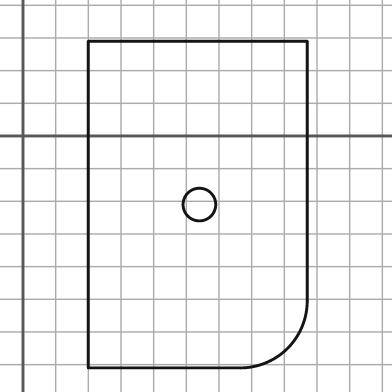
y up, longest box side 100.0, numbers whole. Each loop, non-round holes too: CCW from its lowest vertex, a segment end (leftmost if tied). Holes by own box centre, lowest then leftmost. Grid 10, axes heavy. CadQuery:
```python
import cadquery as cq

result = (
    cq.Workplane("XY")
    .moveTo(20.0, -71.0)
    .lineTo(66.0, -71.0)
    .threePointArc((81.0, -65.0), (87.0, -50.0))
    .lineTo(87.0, 29.0)
    .lineTo(20.0, 29.0)
    .close()
    .moveTo(54.0, -21.0)
    .circle(5.0)
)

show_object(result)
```